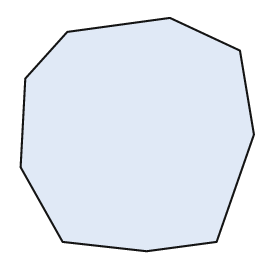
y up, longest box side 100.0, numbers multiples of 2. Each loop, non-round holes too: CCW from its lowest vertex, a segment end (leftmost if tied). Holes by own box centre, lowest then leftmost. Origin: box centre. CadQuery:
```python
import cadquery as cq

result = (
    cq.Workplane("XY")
    .moveTo(4.0, -50.0)
    .lineTo(34.0, -46.0)
    .lineTo(50.0, 0.0)
    .lineTo(44.0, 36.0)
    .lineTo(14.0, 50.0)
    .lineTo(-30.0, 44.0)
    .lineTo(-48.0, 24.0)
    .lineTo(-50.0, -14.0)
    .lineTo(-32.0, -46.0)
    .close()
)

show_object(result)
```